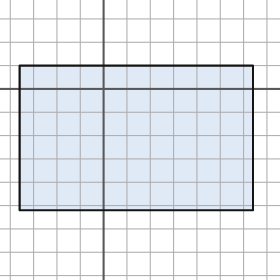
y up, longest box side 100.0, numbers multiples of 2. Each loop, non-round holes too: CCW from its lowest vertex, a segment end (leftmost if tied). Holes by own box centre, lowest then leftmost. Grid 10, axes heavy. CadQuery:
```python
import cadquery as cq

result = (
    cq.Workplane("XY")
    .moveTo(-36.0, -52.0)
    .lineTo(64.0, -52.0)
    .lineTo(64.0, 10.0)
    .lineTo(-36.0, 10.0)
    .close()
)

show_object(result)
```